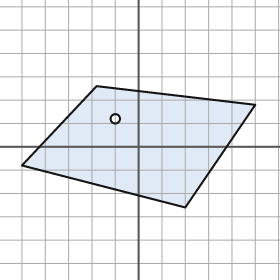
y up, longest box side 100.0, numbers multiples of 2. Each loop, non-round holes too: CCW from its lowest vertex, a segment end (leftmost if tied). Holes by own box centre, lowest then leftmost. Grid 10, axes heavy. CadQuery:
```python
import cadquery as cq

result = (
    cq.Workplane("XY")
    .moveTo(20.0, -26.0)
    .lineTo(50.0, 18.0)
    .lineTo(-18.0, 26.0)
    .lineTo(-50.0, -8.0)
    .close()
    .moveTo(-10.0, 12.0)
    .circle(2.0)
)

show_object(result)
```